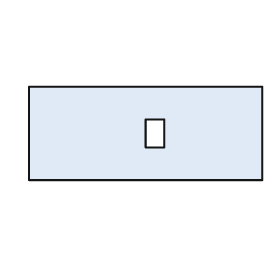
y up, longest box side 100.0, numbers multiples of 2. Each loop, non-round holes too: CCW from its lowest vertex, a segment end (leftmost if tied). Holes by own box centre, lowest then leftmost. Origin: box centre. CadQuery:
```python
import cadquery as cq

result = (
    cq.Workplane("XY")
    .moveTo(-50.0, -20.0)
    .lineTo(50.0, -20.0)
    .lineTo(50.0, 20.0)
    .lineTo(-50.0, 20.0)
    .close()
    .moveTo(0.0, -6.0)
    .lineTo(8.0, -6.0)
    .lineTo(8.0, 6.0)
    .lineTo(0.0, 6.0)
    .close()
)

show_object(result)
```